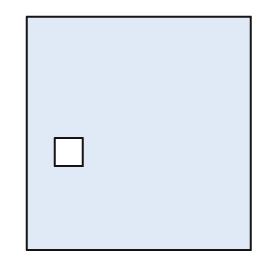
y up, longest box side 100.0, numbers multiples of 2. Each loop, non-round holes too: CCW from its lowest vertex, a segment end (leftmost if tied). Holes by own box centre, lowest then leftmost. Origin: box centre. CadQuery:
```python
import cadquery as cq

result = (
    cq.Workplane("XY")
    .moveTo(-48.0, -50.0)
    .lineTo(48.0, -50.0)
    .lineTo(48.0, 50.0)
    .lineTo(-48.0, 50.0)
    .close()
    .moveTo(-36.0, -14.0)
    .lineTo(-24.0, -14.0)
    .lineTo(-24.0, -2.0)
    .lineTo(-36.0, -2.0)
    .close()
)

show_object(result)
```